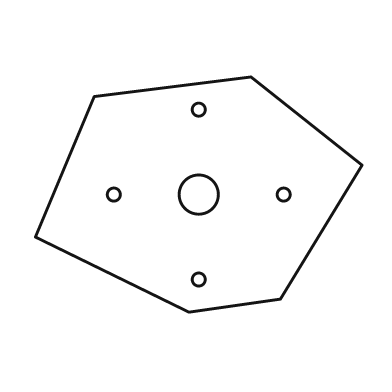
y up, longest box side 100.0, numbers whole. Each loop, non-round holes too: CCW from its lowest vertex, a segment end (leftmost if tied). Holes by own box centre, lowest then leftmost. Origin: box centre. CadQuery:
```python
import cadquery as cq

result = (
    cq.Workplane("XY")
    .moveTo(-3.0, -36.0)
    .lineTo(25.0, -32.0)
    .lineTo(50.0, 9.0)
    .lineTo(16.0, 36.0)
    .lineTo(-32.0, 30.0)
    .lineTo(-50.0, -13.0)
    .close()
    .moveTo(0.0, -26.0)
    .circle(2.0)
    .moveTo(-26.0, 0.0)
    .circle(2.0)
    .moveTo(0.0, 0.0)
    .circle(6.0)
    .moveTo(26.0, 0.0)
    .circle(2.0)
    .moveTo(0.0, 26.0)
    .circle(2.0)
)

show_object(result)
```